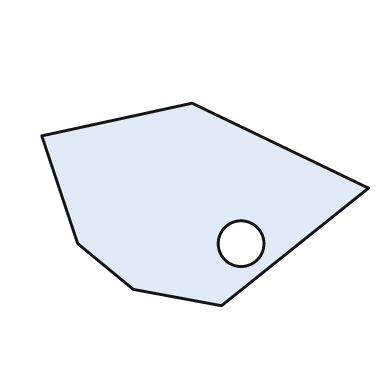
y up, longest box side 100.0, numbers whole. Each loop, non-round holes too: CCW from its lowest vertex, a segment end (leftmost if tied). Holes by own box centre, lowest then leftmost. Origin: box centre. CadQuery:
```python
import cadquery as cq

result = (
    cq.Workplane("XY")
    .moveTo(5.0, -31.0)
    .lineTo(50.0, 5.0)
    .lineTo(-4.0, 31.0)
    .lineTo(-50.0, 21.0)
    .lineTo(-39.0, -12.0)
    .lineTo(-22.0, -26.0)
    .close()
    .moveTo(11.0, -12.0)
    .circle(7.0)
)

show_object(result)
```